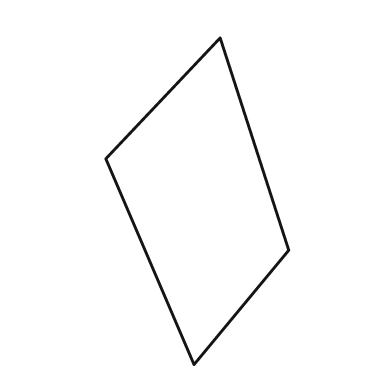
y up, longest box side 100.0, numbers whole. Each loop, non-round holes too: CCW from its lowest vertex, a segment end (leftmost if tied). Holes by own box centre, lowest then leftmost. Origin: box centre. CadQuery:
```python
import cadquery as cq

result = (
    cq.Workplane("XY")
    .moveTo(-1.0, -50.0)
    .lineTo(28.0, -15.0)
    .lineTo(7.0, 50.0)
    .lineTo(-28.0, 13.0)
    .close()
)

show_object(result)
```